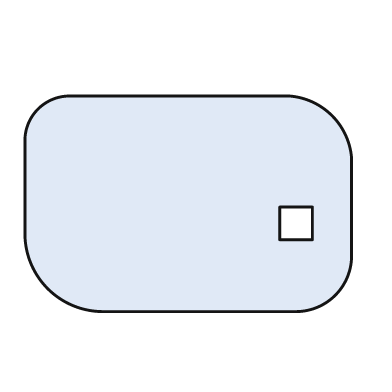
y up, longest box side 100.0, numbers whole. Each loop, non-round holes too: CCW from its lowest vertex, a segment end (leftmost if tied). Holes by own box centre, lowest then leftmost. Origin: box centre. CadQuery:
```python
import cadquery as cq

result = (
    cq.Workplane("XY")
    .moveTo(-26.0, -33.0)
    .lineTo(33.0, -33.0)
    .threePointArc((45.0, -28.0), (50.0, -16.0))
    .lineTo(50.0, 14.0)
    .threePointArc((44.0, 27.0), (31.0, 33.0))
    .lineTo(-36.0, 33.0)
    .threePointArc((-46.0, 29.0), (-50.0, 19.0))
    .lineTo(-50.0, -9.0)
    .threePointArc((-43.0, -26.0), (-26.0, -33.0))
    .close()
    .moveTo(28.0, -11.0)
    .lineTo(38.0, -11.0)
    .lineTo(38.0, -1.0)
    .lineTo(28.0, -1.0)
    .close()
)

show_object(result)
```